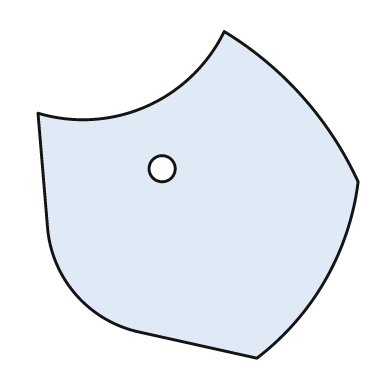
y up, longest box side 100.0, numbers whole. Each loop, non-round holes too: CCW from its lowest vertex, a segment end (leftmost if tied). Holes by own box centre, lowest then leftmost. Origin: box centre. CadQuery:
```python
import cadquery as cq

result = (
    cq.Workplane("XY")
    .moveTo(18.0, -50.0)
    .threePointArc((39.0, -26.0), (49.0, 4.0))
    .threePointArc((32.0, 30.0), (8.0, 50.0))
    .threePointArc((-16.0, 27.0), (-49.0, 25.0))
    .lineTo(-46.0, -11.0)
    .threePointArc((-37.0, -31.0), (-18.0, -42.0))
    .close()
    .moveTo(-11.0, 8.0)
    .circle(4.0)
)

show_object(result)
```